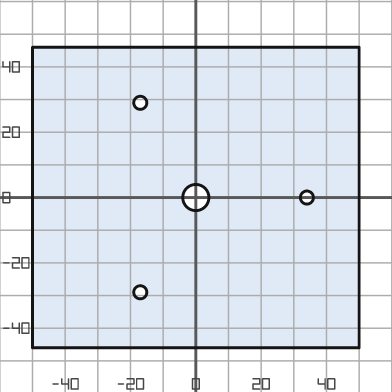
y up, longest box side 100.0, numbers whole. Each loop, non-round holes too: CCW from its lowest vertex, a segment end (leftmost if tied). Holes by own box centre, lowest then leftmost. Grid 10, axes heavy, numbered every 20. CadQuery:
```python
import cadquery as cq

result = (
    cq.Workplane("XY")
    .moveTo(-50.0, -46.0)
    .lineTo(50.0, -46.0)
    .lineTo(50.0, 46.0)
    .lineTo(-50.0, 46.0)
    .close()
    .moveTo(-17.0, -29.0)
    .circle(2.0)
    .moveTo(0.0, 0.0)
    .circle(4.0)
    .moveTo(34.0, 0.0)
    .circle(2.0)
    .moveTo(-17.0, 29.0)
    .circle(2.0)
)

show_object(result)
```